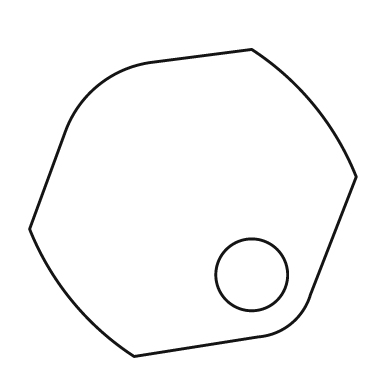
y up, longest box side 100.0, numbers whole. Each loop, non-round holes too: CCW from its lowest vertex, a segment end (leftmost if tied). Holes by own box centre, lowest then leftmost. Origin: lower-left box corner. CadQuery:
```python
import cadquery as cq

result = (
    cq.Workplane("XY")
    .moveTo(32.0, 0.0)
    .lineTo(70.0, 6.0)
    .threePointArc((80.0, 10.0), (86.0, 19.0))
    .lineTo(100.0, 55.0)
    .threePointArc((87.0, 77.0), (68.0, 94.0))
    .lineTo(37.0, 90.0)
    .threePointArc((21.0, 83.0), (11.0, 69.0))
    .lineTo(0.0, 39.0)
    .threePointArc((13.0, 17.0), (32.0, 0.0))
    .close()
    .moveTo(68.0, 25.0)
    .circle(11.0)
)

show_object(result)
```